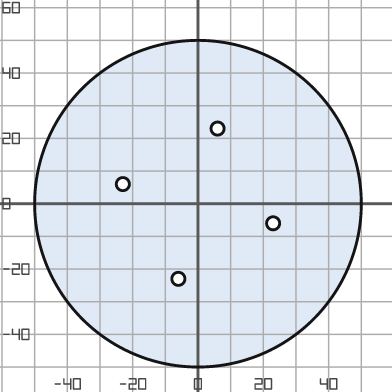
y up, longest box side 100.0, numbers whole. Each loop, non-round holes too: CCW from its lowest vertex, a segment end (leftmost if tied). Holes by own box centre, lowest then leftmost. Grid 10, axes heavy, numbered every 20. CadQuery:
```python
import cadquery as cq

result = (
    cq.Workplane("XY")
    .moveTo(0.0, 0.0)
    .circle(50.0)
    .moveTo(-6.0, -23.0)
    .circle(2.0)
    .moveTo(23.0, -6.0)
    .circle(2.0)
    .moveTo(-23.0, 6.0)
    .circle(2.0)
    .moveTo(6.0, 23.0)
    .circle(2.0)
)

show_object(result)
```